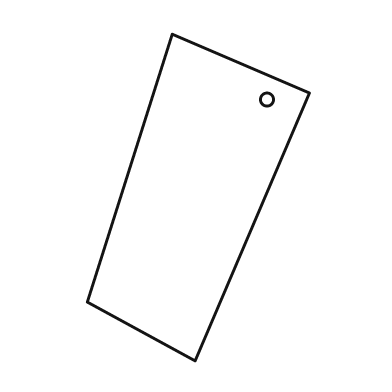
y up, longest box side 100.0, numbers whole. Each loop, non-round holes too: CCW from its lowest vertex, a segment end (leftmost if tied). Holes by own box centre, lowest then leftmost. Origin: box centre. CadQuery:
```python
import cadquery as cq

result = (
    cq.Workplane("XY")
    .moveTo(-1.0, -50.0)
    .lineTo(34.0, 32.0)
    .lineTo(-8.0, 50.0)
    .lineTo(-34.0, -32.0)
    .close()
    .moveTo(21.0, 30.0)
    .circle(2.0)
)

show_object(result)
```